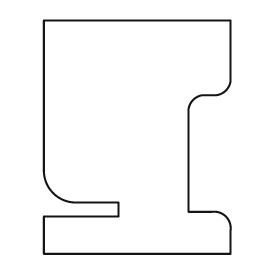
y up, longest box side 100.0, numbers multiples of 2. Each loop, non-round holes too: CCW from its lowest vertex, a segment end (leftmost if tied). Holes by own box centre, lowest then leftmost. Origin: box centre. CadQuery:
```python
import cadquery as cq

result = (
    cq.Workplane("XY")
    .moveTo(-40.0, -50.0)
    .lineTo(40.0, -50.0)
    .lineTo(40.0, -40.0)
    .threePointArc((38.0, -34.0), (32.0, -32.0))
    .lineTo(22.0, -32.0)
    .lineTo(22.0, 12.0)
    .threePointArc((24.0, 16.0), (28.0, 18.0))
    .lineTo(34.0, 18.0)
    .threePointArc((38.0, 20.0), (40.0, 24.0))
    .lineTo(40.0, 50.0)
    .lineTo(-40.0, 50.0)
    .lineTo(-40.0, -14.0)
    .threePointArc((-36.0, -24.0), (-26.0, -28.0))
    .lineTo(-8.0, -28.0)
    .lineTo(-8.0, -34.0)
    .lineTo(-40.0, -34.0)
    .close()
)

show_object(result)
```